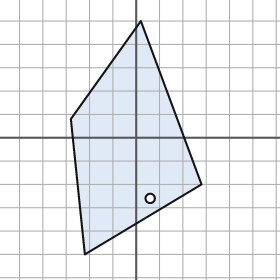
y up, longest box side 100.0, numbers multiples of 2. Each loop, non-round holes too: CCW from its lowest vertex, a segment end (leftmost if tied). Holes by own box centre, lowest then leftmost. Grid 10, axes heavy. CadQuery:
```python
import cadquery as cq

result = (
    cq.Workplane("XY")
    .moveTo(-22.0, -50.0)
    .lineTo(28.0, -20.0)
    .lineTo(2.0, 50.0)
    .lineTo(-28.0, 8.0)
    .close()
    .moveTo(6.0, -26.0)
    .circle(2.0)
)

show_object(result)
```